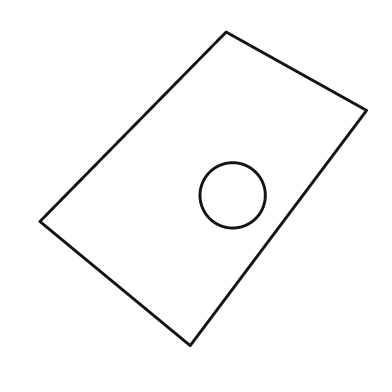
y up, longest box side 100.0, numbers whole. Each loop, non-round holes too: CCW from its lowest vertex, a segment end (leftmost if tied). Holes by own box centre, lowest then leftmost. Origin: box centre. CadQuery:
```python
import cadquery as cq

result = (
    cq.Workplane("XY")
    .moveTo(-4.0, -48.0)
    .lineTo(50.0, 24.0)
    .lineTo(7.0, 48.0)
    .lineTo(-50.0, -10.0)
    .close()
    .moveTo(9.0, -2.0)
    .circle(10.0)
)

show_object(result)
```